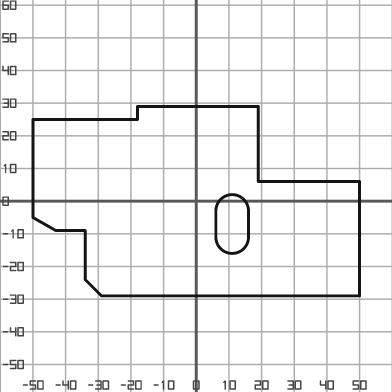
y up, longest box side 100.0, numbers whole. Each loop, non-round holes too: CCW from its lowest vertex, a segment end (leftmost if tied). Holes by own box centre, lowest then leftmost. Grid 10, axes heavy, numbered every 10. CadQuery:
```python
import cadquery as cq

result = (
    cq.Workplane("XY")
    .moveTo(-29.0, -29.0)
    .lineTo(50.0, -29.0)
    .lineTo(50.0, 6.0)
    .lineTo(19.0, 6.0)
    .lineTo(19.0, 29.0)
    .lineTo(-18.0, 29.0)
    .lineTo(-18.0, 25.0)
    .lineTo(-50.0, 25.0)
    .lineTo(-50.0, -5.0)
    .lineTo(-43.0, -9.0)
    .lineTo(-34.0, -9.0)
    .lineTo(-34.0, -24.0)
    .close()
    .moveTo(6.0, -11.0)
    .threePointArc((11.0, -16.0), (16.0, -11.0))
    .lineTo(16.0, -3.0)
    .threePointArc((11.0, 2.0), (6.0, -3.0))
    .close()
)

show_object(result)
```